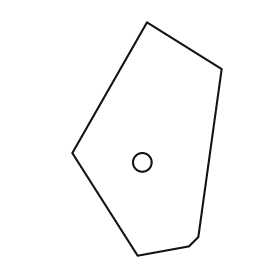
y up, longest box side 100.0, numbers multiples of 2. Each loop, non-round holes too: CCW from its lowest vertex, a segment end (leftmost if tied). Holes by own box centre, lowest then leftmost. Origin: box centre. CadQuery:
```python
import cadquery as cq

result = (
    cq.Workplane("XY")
    .moveTo(-4.0, -50.0)
    .lineTo(18.0, -46.0)
    .lineTo(22.0, -42.0)
    .lineTo(32.0, 30.0)
    .lineTo(0.0, 50.0)
    .lineTo(-32.0, -6.0)
    .close()
    .moveTo(-2.0, -10.0)
    .circle(4.0)
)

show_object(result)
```